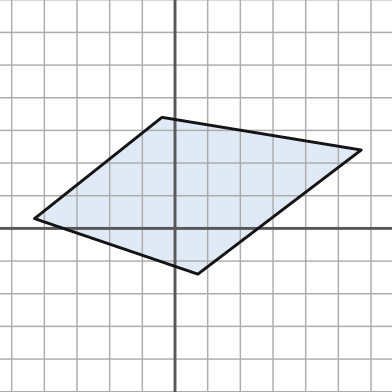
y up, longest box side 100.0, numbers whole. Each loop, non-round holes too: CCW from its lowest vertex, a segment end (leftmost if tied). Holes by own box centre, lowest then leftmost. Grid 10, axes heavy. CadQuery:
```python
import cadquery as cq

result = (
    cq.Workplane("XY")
    .moveTo(7.0, -14.0)
    .lineTo(57.0, 24.0)
    .lineTo(-4.0, 34.0)
    .lineTo(-43.0, 3.0)
    .close()
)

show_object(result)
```